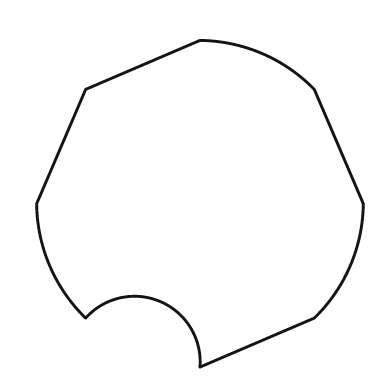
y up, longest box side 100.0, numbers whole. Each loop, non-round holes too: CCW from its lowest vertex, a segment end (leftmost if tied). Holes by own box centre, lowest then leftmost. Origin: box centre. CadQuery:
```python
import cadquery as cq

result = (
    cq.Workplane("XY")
    .moveTo(0.0, -50.0)
    .lineTo(35.0, -35.0)
    .threePointArc((46.0, -19.0), (50.0, 0.0))
    .lineTo(35.0, 35.0)
    .threePointArc((19.0, 46.0), (0.0, 50.0))
    .lineTo(-35.0, 35.0)
    .lineTo(-50.0, 0.0)
    .threePointArc((-46.0, -19.0), (-35.0, -35.0))
    .threePointArc((-12.0, -30.0), (0.0, -50.0))
    .close()
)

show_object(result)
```